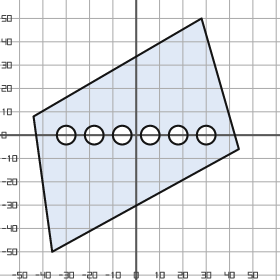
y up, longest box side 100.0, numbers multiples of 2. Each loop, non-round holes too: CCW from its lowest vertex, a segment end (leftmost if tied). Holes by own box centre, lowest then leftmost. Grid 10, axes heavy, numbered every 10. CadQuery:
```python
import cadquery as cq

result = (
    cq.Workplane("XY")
    .moveTo(-36.0, -50.0)
    .lineTo(44.0, -6.0)
    .lineTo(28.0, 50.0)
    .lineTo(-44.0, 8.0)
    .close()
    .moveTo(-30.0, 0.0)
    .circle(4.0)
    .moveTo(-18.0, 0.0)
    .circle(4.0)
    .moveTo(-6.0, 0.0)
    .circle(4.0)
    .moveTo(6.0, 0.0)
    .circle(4.0)
    .moveTo(18.0, 0.0)
    .circle(4.0)
    .moveTo(30.0, 0.0)
    .circle(4.0)
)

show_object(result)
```